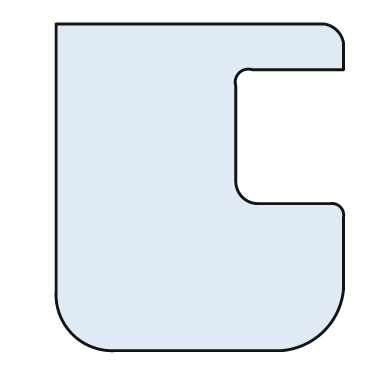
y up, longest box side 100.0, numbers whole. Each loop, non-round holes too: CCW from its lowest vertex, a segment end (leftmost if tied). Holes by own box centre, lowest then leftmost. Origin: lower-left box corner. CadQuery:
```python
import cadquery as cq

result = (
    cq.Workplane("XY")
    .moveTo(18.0, 0.0)
    .lineTo(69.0, 0.0)
    .threePointArc((82.0, 6.0), (88.0, 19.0))
    .lineTo(88.0, 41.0)
    .threePointArc((87.0, 44.0), (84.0, 45.0))
    .lineTo(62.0, 45.0)
    .threePointArc((57.0, 47.0), (55.0, 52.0))
    .lineTo(55.0, 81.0)
    .threePointArc((56.0, 85.0), (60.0, 86.0))
    .lineTo(88.0, 86.0)
    .lineTo(88.0, 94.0)
    .threePointArc((86.0, 98.0), (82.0, 100.0))
    .lineTo(0.0, 100.0)
    .lineTo(0.0, 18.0)
    .threePointArc((5.0, 5.0), (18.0, 0.0))
    .close()
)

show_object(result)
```